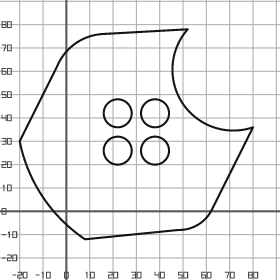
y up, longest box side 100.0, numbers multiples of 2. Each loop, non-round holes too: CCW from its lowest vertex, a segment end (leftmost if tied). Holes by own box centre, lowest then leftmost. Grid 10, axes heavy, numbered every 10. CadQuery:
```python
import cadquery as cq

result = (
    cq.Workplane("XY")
    .moveTo(8.0, -12.0)
    .lineTo(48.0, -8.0)
    .threePointArc((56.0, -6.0), (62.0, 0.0))
    .lineTo(80.0, 36.0)
    .threePointArc((50.0, 46.0), (52.0, 78.0))
    .lineTo(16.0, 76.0)
    .threePointArc((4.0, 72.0), (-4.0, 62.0))
    .lineTo(-20.0, 30.0)
    .threePointArc((-10.0, 6.0), (8.0, -12.0))
    .close()
    .moveTo(22.0, 26.0)
    .circle(6.0)
    .moveTo(38.0, 26.0)
    .circle(6.0)
    .moveTo(22.0, 42.0)
    .circle(6.0)
    .moveTo(38.0, 42.0)
    .circle(6.0)
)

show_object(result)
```